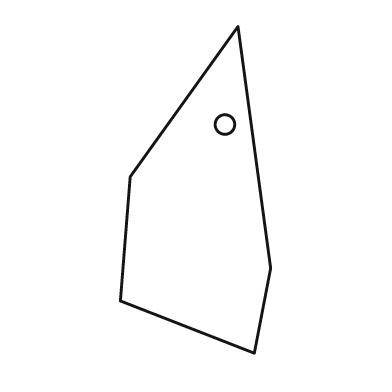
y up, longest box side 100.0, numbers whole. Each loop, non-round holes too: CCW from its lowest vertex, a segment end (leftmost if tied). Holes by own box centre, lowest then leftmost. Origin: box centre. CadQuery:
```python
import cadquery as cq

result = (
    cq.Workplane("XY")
    .moveTo(18.0, -50.0)
    .lineTo(23.0, -24.0)
    .lineTo(13.0, 50.0)
    .lineTo(-20.0, 4.0)
    .lineTo(-23.0, -34.0)
    .close()
    .moveTo(9.0, 20.0)
    .circle(3.0)
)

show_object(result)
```